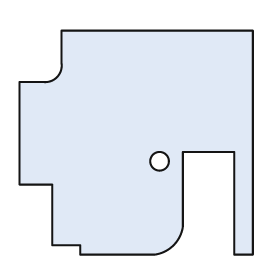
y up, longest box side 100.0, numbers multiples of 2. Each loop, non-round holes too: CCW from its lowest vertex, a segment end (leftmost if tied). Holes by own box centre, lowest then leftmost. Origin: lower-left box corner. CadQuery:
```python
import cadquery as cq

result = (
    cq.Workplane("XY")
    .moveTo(26.0, 0.0)
    .lineTo(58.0, 0.0)
    .threePointArc((66.0, 4.0), (70.0, 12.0))
    .lineTo(70.0, 44.0)
    .lineTo(92.0, 44.0)
    .lineTo(92.0, 0.0)
    .lineTo(100.0, 0.0)
    .lineTo(100.0, 96.0)
    .lineTo(18.0, 96.0)
    .lineTo(18.0, 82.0)
    .threePointArc((16.0, 76.0), (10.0, 74.0))
    .lineTo(0.0, 74.0)
    .lineTo(0.0, 30.0)
    .lineTo(14.0, 30.0)
    .lineTo(14.0, 4.0)
    .lineTo(26.0, 4.0)
    .close()
    .moveTo(60.0, 40.0)
    .circle(4.0)
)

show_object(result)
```